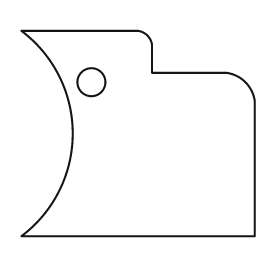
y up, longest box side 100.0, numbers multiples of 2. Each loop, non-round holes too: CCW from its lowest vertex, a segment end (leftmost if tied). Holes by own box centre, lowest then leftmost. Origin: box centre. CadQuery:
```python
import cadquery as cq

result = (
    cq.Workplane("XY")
    .moveTo(-50.0, -44.0)
    .lineTo(50.0, -44.0)
    .lineTo(50.0, 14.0)
    .threePointArc((46.0, 22.0), (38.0, 26.0))
    .lineTo(6.0, 26.0)
    .lineTo(6.0, 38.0)
    .threePointArc((4.0, 42.0), (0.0, 44.0))
    .lineTo(-50.0, 44.0)
    .threePointArc((-28.0, 0.0), (-50.0, -44.0))
    .close()
    .moveTo(-20.0, 22.0)
    .circle(6.0)
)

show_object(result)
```